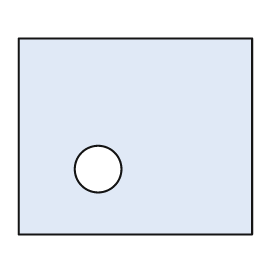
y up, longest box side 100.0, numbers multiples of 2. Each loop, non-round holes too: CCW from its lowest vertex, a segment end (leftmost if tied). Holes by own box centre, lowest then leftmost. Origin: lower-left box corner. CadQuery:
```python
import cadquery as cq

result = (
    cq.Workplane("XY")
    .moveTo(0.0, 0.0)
    .lineTo(100.0, 0.0)
    .lineTo(100.0, 84.0)
    .lineTo(0.0, 84.0)
    .close()
    .moveTo(34.0, 28.0)
    .circle(10.0)
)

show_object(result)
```